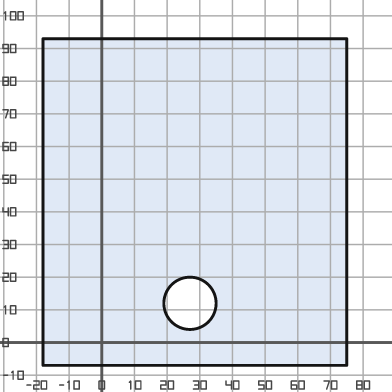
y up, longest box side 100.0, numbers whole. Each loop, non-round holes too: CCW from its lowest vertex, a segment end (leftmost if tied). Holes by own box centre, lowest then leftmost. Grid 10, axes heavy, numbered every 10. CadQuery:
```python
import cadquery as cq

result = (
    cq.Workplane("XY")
    .moveTo(-18.0, -7.0)
    .lineTo(75.0, -7.0)
    .lineTo(75.0, 93.0)
    .lineTo(-18.0, 93.0)
    .close()
    .moveTo(27.0, 12.0)
    .circle(8.0)
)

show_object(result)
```